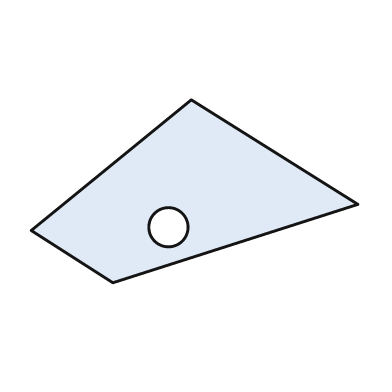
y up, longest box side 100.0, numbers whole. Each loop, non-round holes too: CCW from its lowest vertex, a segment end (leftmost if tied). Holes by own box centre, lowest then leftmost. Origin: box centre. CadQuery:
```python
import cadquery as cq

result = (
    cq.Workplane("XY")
    .moveTo(-25.0, -28.0)
    .lineTo(50.0, -4.0)
    .lineTo(-1.0, 28.0)
    .lineTo(-50.0, -12.0)
    .close()
    .moveTo(-8.0, -11.0)
    .circle(6.0)
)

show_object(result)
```